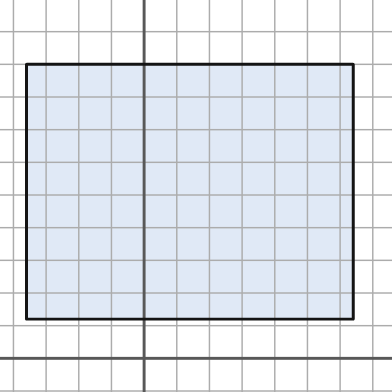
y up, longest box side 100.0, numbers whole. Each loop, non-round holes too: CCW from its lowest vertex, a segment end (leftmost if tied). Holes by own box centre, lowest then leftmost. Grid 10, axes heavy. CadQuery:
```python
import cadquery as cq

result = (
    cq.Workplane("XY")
    .moveTo(-36.0, 12.0)
    .lineTo(64.0, 12.0)
    .lineTo(64.0, 90.0)
    .lineTo(-36.0, 90.0)
    .close()
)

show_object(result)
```